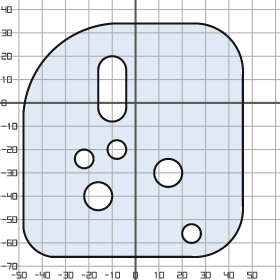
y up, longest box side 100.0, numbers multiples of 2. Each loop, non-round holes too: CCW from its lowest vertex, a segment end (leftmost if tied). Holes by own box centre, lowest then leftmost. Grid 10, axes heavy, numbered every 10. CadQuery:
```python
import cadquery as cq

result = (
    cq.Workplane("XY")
    .moveTo(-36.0, -66.0)
    .lineTo(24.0, -66.0)
    .threePointArc((40.0, -60.0), (46.0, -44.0))
    .lineTo(46.0, 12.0)
    .threePointArc((40.0, 28.0), (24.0, 34.0))
    .lineTo(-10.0, 34.0)
    .threePointArc((-36.0, 22.0), (-48.0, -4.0))
    .lineTo(-48.0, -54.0)
    .threePointArc((-44.0, -62.0), (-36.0, -66.0))
    .close()
    .moveTo(24.0, -56.0)
    .circle(4.0)
    .moveTo(-16.0, -40.0)
    .circle(6.0)
    .moveTo(14.0, -30.0)
    .circle(6.0)
    .moveTo(-22.0, -24.0)
    .circle(4.0)
    .moveTo(-8.0, -20.0)
    .circle(4.0)
    .moveTo(-16.0, -2.0)
    .threePointArc((-10.0, -8.0), (-4.0, -2.0))
    .lineTo(-4.0, 14.0)
    .threePointArc((-10.0, 20.0), (-16.0, 14.0))
    .close()
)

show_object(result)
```